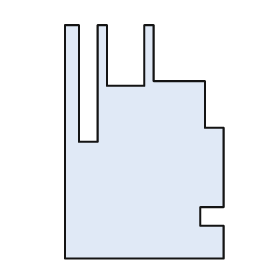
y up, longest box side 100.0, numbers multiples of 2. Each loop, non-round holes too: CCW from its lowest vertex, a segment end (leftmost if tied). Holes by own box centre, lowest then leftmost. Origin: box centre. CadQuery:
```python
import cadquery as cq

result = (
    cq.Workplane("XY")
    .moveTo(-34.0, -50.0)
    .lineTo(34.0, -50.0)
    .lineTo(34.0, -36.0)
    .lineTo(24.0, -36.0)
    .lineTo(24.0, -28.0)
    .lineTo(34.0, -28.0)
    .lineTo(34.0, 6.0)
    .lineTo(26.0, 6.0)
    .lineTo(26.0, 26.0)
    .lineTo(4.0, 26.0)
    .lineTo(4.0, 50.0)
    .lineTo(0.0, 50.0)
    .lineTo(0.0, 24.0)
    .lineTo(-16.0, 24.0)
    .lineTo(-16.0, 50.0)
    .lineTo(-20.0, 50.0)
    .lineTo(-20.0, 0.0)
    .lineTo(-28.0, 0.0)
    .lineTo(-28.0, 50.0)
    .lineTo(-34.0, 50.0)
    .close()
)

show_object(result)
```